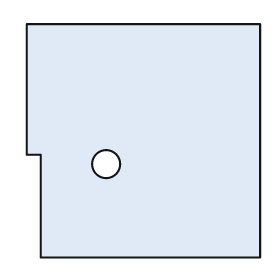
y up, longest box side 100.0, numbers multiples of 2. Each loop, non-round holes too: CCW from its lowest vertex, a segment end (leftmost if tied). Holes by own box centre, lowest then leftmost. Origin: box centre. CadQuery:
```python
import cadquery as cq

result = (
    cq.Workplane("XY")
    .moveTo(-44.0, -50.0)
    .lineTo(50.0, -50.0)
    .lineTo(50.0, 50.0)
    .lineTo(-50.0, 50.0)
    .lineTo(-50.0, -6.0)
    .lineTo(-44.0, -6.0)
    .close()
    .moveTo(-16.0, -10.0)
    .circle(6.0)
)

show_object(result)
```